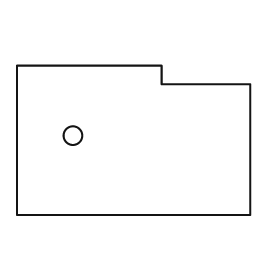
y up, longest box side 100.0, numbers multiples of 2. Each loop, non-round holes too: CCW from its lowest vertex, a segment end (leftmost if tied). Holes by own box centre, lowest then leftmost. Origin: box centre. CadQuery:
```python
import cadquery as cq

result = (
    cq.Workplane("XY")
    .moveTo(-50.0, -32.0)
    .lineTo(50.0, -32.0)
    .lineTo(50.0, 24.0)
    .lineTo(12.0, 24.0)
    .lineTo(12.0, 32.0)
    .lineTo(-50.0, 32.0)
    .close()
    .moveTo(-26.0, 2.0)
    .circle(4.0)
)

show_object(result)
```